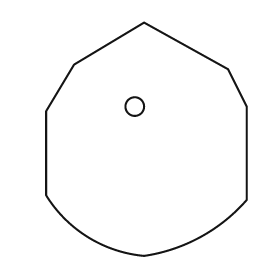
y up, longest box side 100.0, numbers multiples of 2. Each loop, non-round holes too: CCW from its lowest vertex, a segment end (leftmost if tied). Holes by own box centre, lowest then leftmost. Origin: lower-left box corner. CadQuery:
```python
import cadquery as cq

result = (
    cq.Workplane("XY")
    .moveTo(42.0, 0.0)
    .threePointArc((66.0, 8.0), (86.0, 24.0))
    .lineTo(86.0, 64.0)
    .lineTo(78.0, 80.0)
    .lineTo(42.0, 100.0)
    .lineTo(12.0, 82.0)
    .lineTo(0.0, 62.0)
    .lineTo(0.0, 26.0)
    .threePointArc((18.0, 8.0), (42.0, 0.0))
    .close()
    .moveTo(38.0, 64.0)
    .circle(4.0)
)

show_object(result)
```